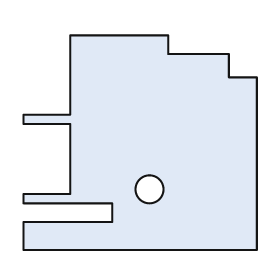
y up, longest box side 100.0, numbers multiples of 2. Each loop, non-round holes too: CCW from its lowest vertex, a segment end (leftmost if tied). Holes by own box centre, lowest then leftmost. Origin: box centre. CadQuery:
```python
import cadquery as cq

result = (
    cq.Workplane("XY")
    .moveTo(-50.0, -46.0)
    .lineTo(50.0, -46.0)
    .lineTo(50.0, 28.0)
    .lineTo(38.0, 28.0)
    .lineTo(38.0, 38.0)
    .lineTo(12.0, 38.0)
    .lineTo(12.0, 46.0)
    .lineTo(-30.0, 46.0)
    .lineTo(-30.0, 12.0)
    .lineTo(-50.0, 12.0)
    .lineTo(-50.0, 8.0)
    .lineTo(-30.0, 8.0)
    .lineTo(-30.0, -22.0)
    .lineTo(-50.0, -22.0)
    .lineTo(-50.0, -26.0)
    .lineTo(-12.0, -26.0)
    .lineTo(-12.0, -34.0)
    .lineTo(-50.0, -34.0)
    .close()
    .moveTo(4.0, -20.0)
    .circle(6.0)
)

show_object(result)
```